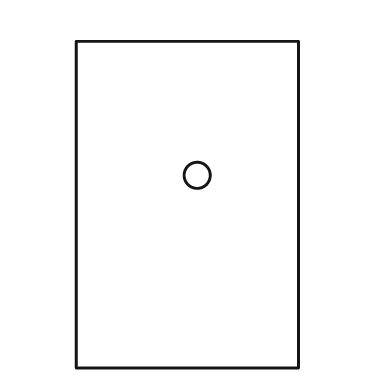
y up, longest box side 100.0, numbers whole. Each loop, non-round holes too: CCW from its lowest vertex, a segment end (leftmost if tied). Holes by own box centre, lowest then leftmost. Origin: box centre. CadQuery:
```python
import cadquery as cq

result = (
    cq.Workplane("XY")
    .moveTo(-34.0, -50.0)
    .lineTo(34.0, -50.0)
    .lineTo(34.0, 50.0)
    .lineTo(-34.0, 50.0)
    .close()
    .moveTo(3.0, 9.0)
    .circle(4.0)
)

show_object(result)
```